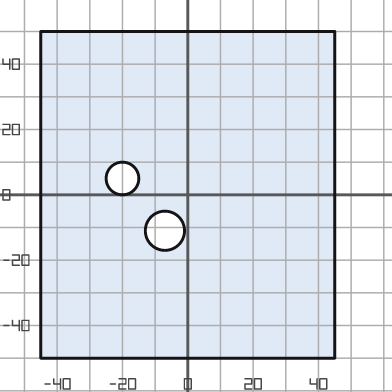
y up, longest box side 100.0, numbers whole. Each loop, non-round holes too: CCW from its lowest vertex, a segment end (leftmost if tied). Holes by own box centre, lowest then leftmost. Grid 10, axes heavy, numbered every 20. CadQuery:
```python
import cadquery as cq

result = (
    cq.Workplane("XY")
    .moveTo(-45.0, -50.0)
    .lineTo(45.0, -50.0)
    .lineTo(45.0, 50.0)
    .lineTo(-45.0, 50.0)
    .close()
    .moveTo(-7.0, -11.0)
    .circle(6.0)
    .moveTo(-20.0, 5.0)
    .circle(5.0)
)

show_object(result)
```